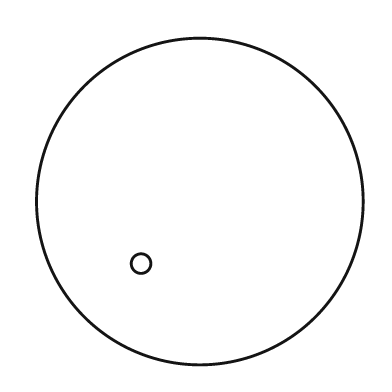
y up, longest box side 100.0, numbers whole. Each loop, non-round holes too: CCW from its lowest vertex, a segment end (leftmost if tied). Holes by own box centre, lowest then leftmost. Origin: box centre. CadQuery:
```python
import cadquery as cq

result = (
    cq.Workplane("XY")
    .moveTo(0.0, 0.0)
    .circle(50.0)
    .moveTo(-18.0, -19.0)
    .circle(3.0)
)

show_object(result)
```